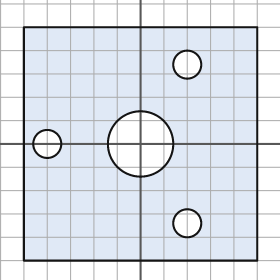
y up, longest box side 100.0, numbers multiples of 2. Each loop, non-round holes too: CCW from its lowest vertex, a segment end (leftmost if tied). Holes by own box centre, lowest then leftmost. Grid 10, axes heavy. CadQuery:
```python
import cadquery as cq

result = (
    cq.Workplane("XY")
    .moveTo(-50.0, -50.0)
    .lineTo(50.0, -50.0)
    .lineTo(50.0, 50.0)
    .lineTo(-50.0, 50.0)
    .close()
    .moveTo(20.0, -34.0)
    .circle(6.0)
    .moveTo(-40.0, 0.0)
    .circle(6.0)
    .moveTo(0.0, 0.0)
    .circle(14.0)
    .moveTo(20.0, 34.0)
    .circle(6.0)
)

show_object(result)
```